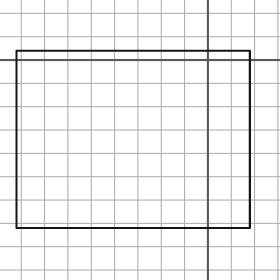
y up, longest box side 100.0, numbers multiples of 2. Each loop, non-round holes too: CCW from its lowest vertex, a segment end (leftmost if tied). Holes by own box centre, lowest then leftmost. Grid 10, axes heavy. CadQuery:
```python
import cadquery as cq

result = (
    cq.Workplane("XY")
    .moveTo(-82.0, -72.0)
    .lineTo(18.0, -72.0)
    .lineTo(18.0, 4.0)
    .lineTo(-82.0, 4.0)
    .close()
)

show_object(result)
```